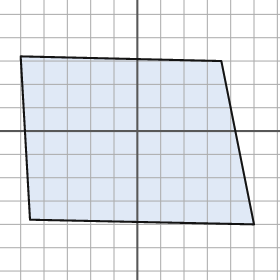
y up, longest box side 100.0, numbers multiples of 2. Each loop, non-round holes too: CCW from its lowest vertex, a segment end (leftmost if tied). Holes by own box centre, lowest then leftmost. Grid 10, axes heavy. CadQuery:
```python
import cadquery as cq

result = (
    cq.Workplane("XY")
    .moveTo(50.0, -40.0)
    .lineTo(36.0, 30.0)
    .lineTo(-50.0, 32.0)
    .lineTo(-46.0, -38.0)
    .close()
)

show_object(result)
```